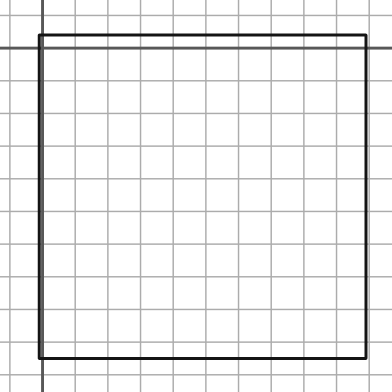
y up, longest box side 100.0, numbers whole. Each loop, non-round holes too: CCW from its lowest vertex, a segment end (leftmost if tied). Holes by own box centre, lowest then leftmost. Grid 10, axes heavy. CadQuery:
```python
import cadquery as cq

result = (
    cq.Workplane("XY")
    .moveTo(-1.0, -95.0)
    .lineTo(99.0, -95.0)
    .lineTo(99.0, 4.0)
    .lineTo(-1.0, 4.0)
    .close()
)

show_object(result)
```